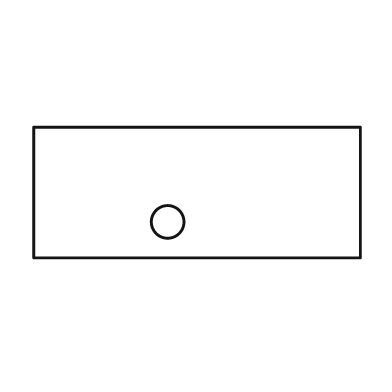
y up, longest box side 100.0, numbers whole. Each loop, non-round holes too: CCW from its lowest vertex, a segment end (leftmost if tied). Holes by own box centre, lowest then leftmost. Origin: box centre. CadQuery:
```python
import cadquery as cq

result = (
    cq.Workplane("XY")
    .moveTo(-50.0, -20.0)
    .lineTo(50.0, -20.0)
    .lineTo(50.0, 20.0)
    .lineTo(-50.0, 20.0)
    .close()
    .moveTo(-9.0, -9.0)
    .circle(5.0)
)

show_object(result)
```